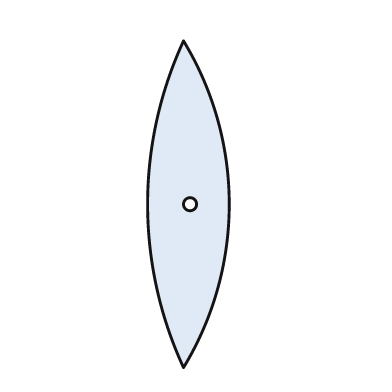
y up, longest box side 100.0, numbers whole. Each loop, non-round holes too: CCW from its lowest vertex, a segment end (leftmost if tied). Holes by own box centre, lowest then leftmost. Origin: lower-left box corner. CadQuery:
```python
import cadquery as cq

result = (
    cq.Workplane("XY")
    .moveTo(11.0, 0.0)
    .threePointArc((25.0, 50.0), (11.0, 100.0))
    .threePointArc((0.0, 50.0), (11.0, 0.0))
    .close()
    .moveTo(13.0, 50.0)
    .circle(2.0)
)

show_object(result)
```